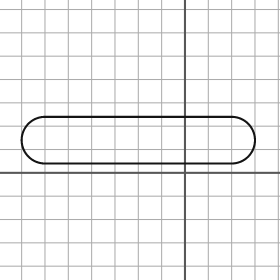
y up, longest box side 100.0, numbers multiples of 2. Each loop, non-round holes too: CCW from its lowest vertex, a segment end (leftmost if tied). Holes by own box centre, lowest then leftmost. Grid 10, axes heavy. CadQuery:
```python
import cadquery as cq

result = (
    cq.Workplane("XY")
    .moveTo(-60.0, 4.0)
    .lineTo(20.0, 4.0)
    .threePointArc((30.0, 14.0), (20.0, 24.0))
    .lineTo(-60.0, 24.0)
    .threePointArc((-70.0, 14.0), (-60.0, 4.0))
    .close()
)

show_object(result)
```